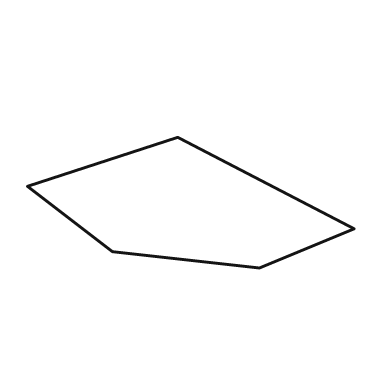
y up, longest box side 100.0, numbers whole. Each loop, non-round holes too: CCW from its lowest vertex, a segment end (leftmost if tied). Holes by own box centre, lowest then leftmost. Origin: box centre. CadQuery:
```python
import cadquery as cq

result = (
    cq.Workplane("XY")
    .moveTo(21.0, -20.0)
    .lineTo(50.0, -8.0)
    .lineTo(-4.0, 20.0)
    .lineTo(-50.0, 5.0)
    .lineTo(-24.0, -15.0)
    .close()
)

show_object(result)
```